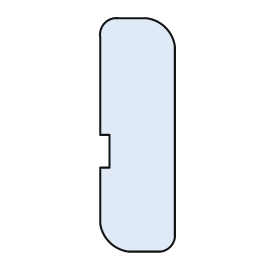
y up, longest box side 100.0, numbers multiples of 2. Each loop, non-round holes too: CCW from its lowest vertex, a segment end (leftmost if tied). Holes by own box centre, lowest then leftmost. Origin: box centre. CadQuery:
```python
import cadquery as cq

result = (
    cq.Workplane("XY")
    .moveTo(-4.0, -50.0)
    .lineTo(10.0, -50.0)
    .threePointArc((14.0, -48.0), (16.0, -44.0))
    .lineTo(16.0, 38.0)
    .threePointArc((12.0, 46.0), (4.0, 50.0))
    .lineTo(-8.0, 50.0)
    .threePointArc((-14.0, 48.0), (-16.0, 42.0))
    .lineTo(-16.0, 0.0)
    .lineTo(-12.0, 0.0)
    .lineTo(-12.0, -14.0)
    .lineTo(-16.0, -14.0)
    .lineTo(-16.0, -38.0)
    .threePointArc((-12.0, -46.0), (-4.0, -50.0))
    .close()
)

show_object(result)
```